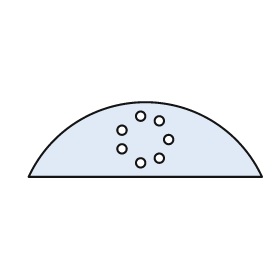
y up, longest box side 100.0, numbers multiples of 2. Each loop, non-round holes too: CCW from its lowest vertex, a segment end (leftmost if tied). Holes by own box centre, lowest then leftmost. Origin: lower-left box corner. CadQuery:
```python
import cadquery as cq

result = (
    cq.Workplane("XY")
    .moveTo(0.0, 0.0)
    .lineTo(100.0, 0.0)
    .threePointArc((50.0, 32.0), (0.0, 0.0))
    .close()
    .moveTo(48.0, 6.0)
    .circle(2.0)
    .moveTo(56.0, 8.0)
    .circle(2.0)
    .moveTo(40.0, 12.0)
    .circle(2.0)
    .moveTo(60.0, 16.0)
    .circle(2.0)
    .moveTo(40.0, 20.0)
    .circle(2.0)
    .moveTo(56.0, 24.0)
    .circle(2.0)
    .moveTo(48.0, 26.0)
    .circle(2.0)
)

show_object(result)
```